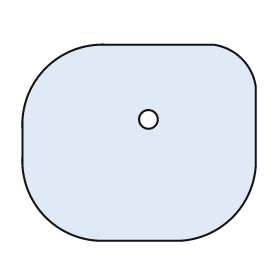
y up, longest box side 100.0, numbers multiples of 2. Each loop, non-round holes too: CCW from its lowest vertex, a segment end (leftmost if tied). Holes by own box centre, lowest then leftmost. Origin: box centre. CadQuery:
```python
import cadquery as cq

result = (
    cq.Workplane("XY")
    .moveTo(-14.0, -42.0)
    .lineTo(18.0, -42.0)
    .threePointArc((40.0, -32.0), (50.0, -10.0))
    .lineTo(50.0, 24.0)
    .threePointArc((44.0, 36.0), (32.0, 42.0))
    .lineTo(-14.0, 42.0)
    .threePointArc((-40.0, 32.0), (-50.0, 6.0))
    .lineTo(-50.0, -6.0)
    .threePointArc((-40.0, -32.0), (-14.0, -42.0))
    .close()
    .moveTo(4.0, 10.0)
    .circle(4.0)
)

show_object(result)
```